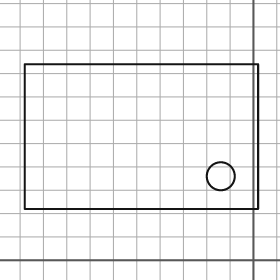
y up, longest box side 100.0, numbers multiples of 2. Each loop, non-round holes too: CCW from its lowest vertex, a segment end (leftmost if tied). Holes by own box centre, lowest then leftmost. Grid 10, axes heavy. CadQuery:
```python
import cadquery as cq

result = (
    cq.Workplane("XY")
    .moveTo(-98.0, 22.0)
    .lineTo(2.0, 22.0)
    .lineTo(2.0, 84.0)
    .lineTo(-98.0, 84.0)
    .close()
    .moveTo(-14.0, 36.0)
    .circle(6.0)
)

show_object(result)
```